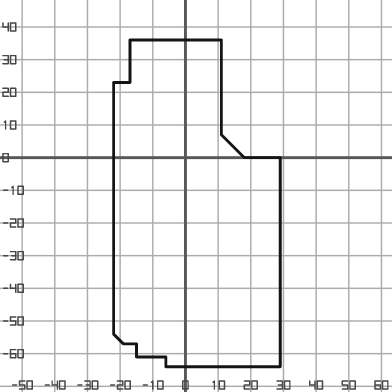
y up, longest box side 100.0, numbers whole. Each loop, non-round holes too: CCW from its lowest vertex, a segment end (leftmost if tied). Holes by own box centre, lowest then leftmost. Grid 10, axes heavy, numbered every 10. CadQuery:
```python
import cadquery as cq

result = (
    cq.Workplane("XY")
    .moveTo(-6.0, -64.0)
    .lineTo(29.0, -64.0)
    .lineTo(29.0, 0.0)
    .lineTo(18.0, 0.0)
    .lineTo(11.0, 7.0)
    .lineTo(11.0, 36.0)
    .lineTo(-17.0, 36.0)
    .lineTo(-17.0, 23.0)
    .lineTo(-22.0, 23.0)
    .lineTo(-22.0, -54.0)
    .lineTo(-19.0, -57.0)
    .lineTo(-15.0, -57.0)
    .lineTo(-15.0, -61.0)
    .lineTo(-6.0, -61.0)
    .close()
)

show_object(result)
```